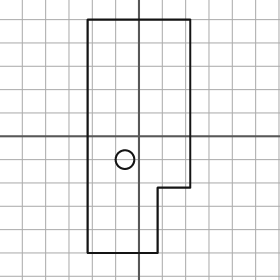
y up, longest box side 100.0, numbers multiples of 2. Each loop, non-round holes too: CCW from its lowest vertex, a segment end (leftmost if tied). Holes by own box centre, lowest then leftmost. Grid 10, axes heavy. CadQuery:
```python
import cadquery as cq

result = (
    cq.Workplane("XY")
    .moveTo(-22.0, -50.0)
    .lineTo(8.0, -50.0)
    .lineTo(8.0, -22.0)
    .lineTo(22.0, -22.0)
    .lineTo(22.0, 50.0)
    .lineTo(-22.0, 50.0)
    .close()
    .moveTo(-6.0, -10.0)
    .circle(4.0)
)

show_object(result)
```